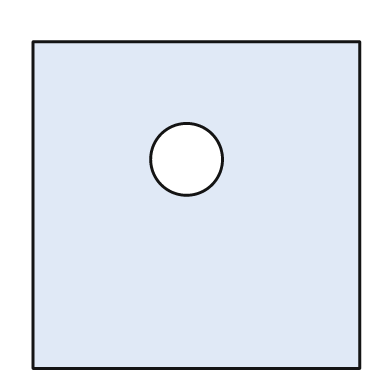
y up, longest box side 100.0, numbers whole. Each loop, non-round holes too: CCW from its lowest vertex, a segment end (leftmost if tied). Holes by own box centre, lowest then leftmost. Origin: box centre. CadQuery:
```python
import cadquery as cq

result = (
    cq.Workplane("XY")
    .moveTo(-50.0, -50.0)
    .lineTo(50.0, -50.0)
    .lineTo(50.0, 50.0)
    .lineTo(-50.0, 50.0)
    .close()
    .moveTo(-3.0, 14.0)
    .circle(11.0)
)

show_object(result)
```